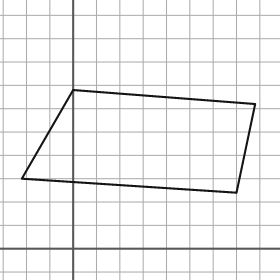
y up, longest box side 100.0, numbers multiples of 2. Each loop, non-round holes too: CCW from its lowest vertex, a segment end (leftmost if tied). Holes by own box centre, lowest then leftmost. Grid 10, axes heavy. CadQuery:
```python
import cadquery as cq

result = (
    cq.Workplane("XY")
    .moveTo(70.0, 24.0)
    .lineTo(78.0, 62.0)
    .lineTo(0.0, 68.0)
    .lineTo(-22.0, 30.0)
    .close()
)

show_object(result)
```